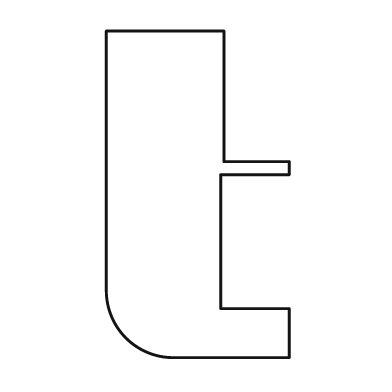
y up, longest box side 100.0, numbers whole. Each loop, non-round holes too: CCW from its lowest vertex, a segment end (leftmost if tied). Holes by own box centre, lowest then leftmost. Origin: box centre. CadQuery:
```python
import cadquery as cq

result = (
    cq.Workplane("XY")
    .moveTo(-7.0, -50.0)
    .lineTo(28.0, -50.0)
    .lineTo(28.0, -35.0)
    .lineTo(7.0, -35.0)
    .lineTo(7.0, 6.0)
    .lineTo(28.0, 6.0)
    .lineTo(28.0, 10.0)
    .lineTo(8.0, 10.0)
    .lineTo(8.0, 50.0)
    .lineTo(-28.0, 50.0)
    .lineTo(-28.0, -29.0)
    .threePointArc((-22.0, -44.0), (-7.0, -50.0))
    .close()
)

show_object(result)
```